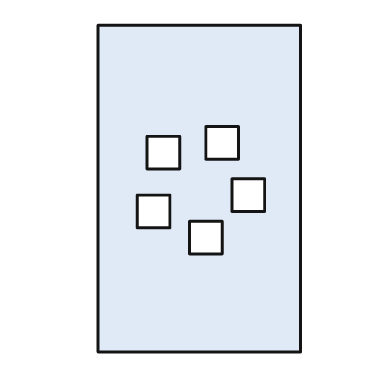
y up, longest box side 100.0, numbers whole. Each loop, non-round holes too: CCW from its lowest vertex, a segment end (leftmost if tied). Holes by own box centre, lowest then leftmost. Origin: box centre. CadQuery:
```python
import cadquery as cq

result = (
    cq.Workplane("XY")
    .moveTo(-31.0, -50.0)
    .lineTo(31.0, -50.0)
    .lineTo(31.0, 50.0)
    .lineTo(-31.0, 50.0)
    .close()
    .moveTo(-3.0, -20.0)
    .lineTo(7.0, -20.0)
    .lineTo(7.0, -10.0)
    .lineTo(-3.0, -10.0)
    .close()
    .moveTo(-19.0, -12.0)
    .lineTo(-9.0, -12.0)
    .lineTo(-9.0, -2.0)
    .lineTo(-19.0, -2.0)
    .close()
    .moveTo(10.0, -7.0)
    .lineTo(20.0, -7.0)
    .lineTo(20.0, 3.0)
    .lineTo(10.0, 3.0)
    .close()
    .moveTo(-16.0, 6.0)
    .lineTo(-6.0, 6.0)
    .lineTo(-6.0, 16.0)
    .lineTo(-16.0, 16.0)
    .close()
    .moveTo(2.0, 9.0)
    .lineTo(12.0, 9.0)
    .lineTo(12.0, 19.0)
    .lineTo(2.0, 19.0)
    .close()
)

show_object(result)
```